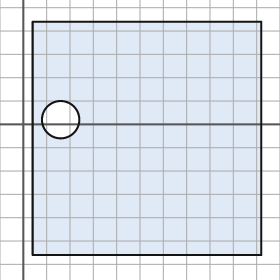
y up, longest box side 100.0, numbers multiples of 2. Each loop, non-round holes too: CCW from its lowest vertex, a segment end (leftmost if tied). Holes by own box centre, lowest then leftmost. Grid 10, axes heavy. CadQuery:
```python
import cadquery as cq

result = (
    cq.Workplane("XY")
    .moveTo(4.0, -56.0)
    .lineTo(102.0, -56.0)
    .lineTo(102.0, 44.0)
    .lineTo(4.0, 44.0)
    .close()
    .moveTo(16.0, 2.0)
    .circle(8.0)
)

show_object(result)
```